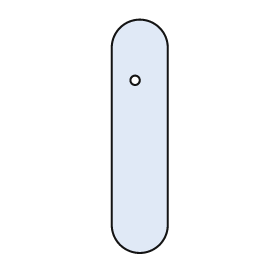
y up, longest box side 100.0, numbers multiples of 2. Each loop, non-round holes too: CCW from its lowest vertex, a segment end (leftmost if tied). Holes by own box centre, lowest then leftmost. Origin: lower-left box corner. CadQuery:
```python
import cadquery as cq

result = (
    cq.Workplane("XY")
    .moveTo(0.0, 12.0)
    .threePointArc((12.0, 0.0), (24.0, 12.0))
    .lineTo(24.0, 88.0)
    .threePointArc((12.0, 100.0), (0.0, 88.0))
    .close()
    .moveTo(10.0, 74.0)
    .circle(2.0)
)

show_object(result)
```